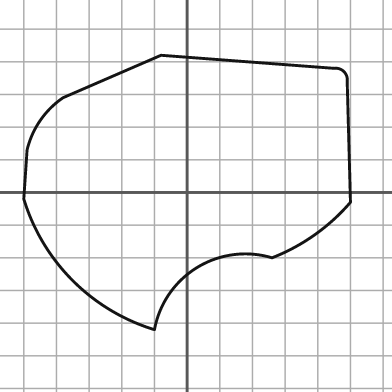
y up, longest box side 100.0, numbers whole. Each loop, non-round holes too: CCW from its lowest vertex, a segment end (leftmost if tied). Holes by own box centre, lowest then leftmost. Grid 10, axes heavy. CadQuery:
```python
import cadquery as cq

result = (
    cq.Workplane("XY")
    .moveTo(-10.0, -42.0)
    .threePointArc((3.0, -23.0), (26.0, -20.0))
    .threePointArc((39.0, -13.0), (50.0, -3.0))
    .lineTo(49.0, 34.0)
    .threePointArc((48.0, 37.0), (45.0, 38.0))
    .lineTo(-8.0, 42.0)
    .lineTo(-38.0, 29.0)
    .threePointArc((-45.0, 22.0), (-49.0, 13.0))
    .lineTo(-50.0, -2.0)
    .threePointArc((-35.0, -27.0), (-10.0, -42.0))
    .close()
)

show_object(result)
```